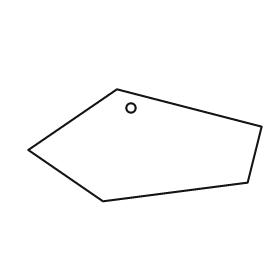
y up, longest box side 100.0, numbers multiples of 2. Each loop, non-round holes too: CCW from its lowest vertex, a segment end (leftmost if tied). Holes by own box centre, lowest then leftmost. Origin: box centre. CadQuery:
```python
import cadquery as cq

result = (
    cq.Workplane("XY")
    .moveTo(-18.0, -24.0)
    .lineTo(44.0, -16.0)
    .lineTo(50.0, 8.0)
    .lineTo(-12.0, 24.0)
    .lineTo(-50.0, -2.0)
    .close()
    .moveTo(-6.0, 16.0)
    .circle(2.0)
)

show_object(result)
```